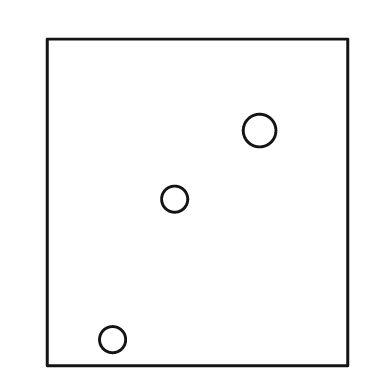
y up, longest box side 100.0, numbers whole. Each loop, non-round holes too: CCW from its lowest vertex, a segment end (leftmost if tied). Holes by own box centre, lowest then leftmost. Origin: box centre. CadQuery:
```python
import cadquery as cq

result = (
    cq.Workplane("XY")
    .moveTo(-46.0, -50.0)
    .lineTo(46.0, -50.0)
    .lineTo(46.0, 50.0)
    .lineTo(-46.0, 50.0)
    .close()
    .moveTo(-26.0, -42.0)
    .circle(4.0)
    .moveTo(-7.0, 1.0)
    .circle(4.0)
    .moveTo(19.0, 22.0)
    .circle(5.0)
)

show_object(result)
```